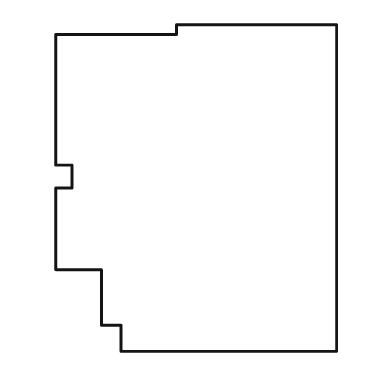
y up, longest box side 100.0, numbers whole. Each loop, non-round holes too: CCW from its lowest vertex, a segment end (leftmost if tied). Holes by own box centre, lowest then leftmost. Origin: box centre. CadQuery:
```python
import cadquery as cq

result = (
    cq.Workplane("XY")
    .moveTo(-23.0, -50.0)
    .lineTo(43.0, -50.0)
    .lineTo(43.0, 50.0)
    .lineTo(-6.0, 50.0)
    .lineTo(-6.0, 47.0)
    .lineTo(-43.0, 47.0)
    .lineTo(-43.0, 7.0)
    .lineTo(-38.0, 7.0)
    .lineTo(-38.0, 0.0)
    .lineTo(-43.0, 0.0)
    .lineTo(-43.0, -25.0)
    .lineTo(-29.0, -25.0)
    .lineTo(-29.0, -42.0)
    .lineTo(-23.0, -42.0)
    .close()
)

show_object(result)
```